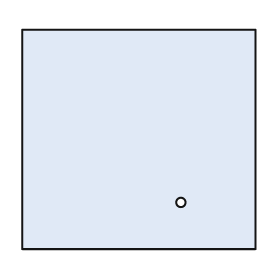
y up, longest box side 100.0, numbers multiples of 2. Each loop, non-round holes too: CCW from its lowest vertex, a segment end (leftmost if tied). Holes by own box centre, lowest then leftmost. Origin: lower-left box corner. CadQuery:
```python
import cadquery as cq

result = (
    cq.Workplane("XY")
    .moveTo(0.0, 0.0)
    .lineTo(100.0, 0.0)
    .lineTo(100.0, 94.0)
    .lineTo(0.0, 94.0)
    .close()
    .moveTo(68.0, 20.0)
    .circle(2.0)
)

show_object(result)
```